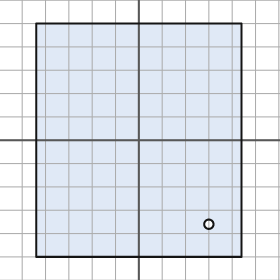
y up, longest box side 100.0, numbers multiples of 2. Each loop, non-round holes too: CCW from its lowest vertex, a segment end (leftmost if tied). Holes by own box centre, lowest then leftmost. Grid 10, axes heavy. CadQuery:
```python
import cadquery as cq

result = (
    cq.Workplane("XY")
    .moveTo(-44.0, -50.0)
    .lineTo(44.0, -50.0)
    .lineTo(44.0, 50.0)
    .lineTo(-44.0, 50.0)
    .close()
    .moveTo(30.0, -36.0)
    .circle(2.0)
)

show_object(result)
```